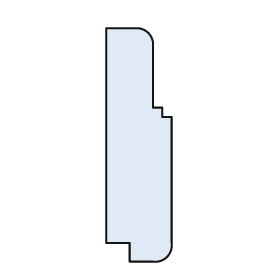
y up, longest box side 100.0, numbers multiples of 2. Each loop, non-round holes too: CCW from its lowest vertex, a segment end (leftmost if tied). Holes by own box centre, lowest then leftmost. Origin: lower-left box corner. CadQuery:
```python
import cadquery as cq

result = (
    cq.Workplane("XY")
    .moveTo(10.0, 0.0)
    .lineTo(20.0, 0.0)
    .threePointArc((26.0, 2.0), (28.0, 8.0))
    .lineTo(28.0, 62.0)
    .lineTo(24.0, 62.0)
    .lineTo(24.0, 66.0)
    .lineTo(20.0, 66.0)
    .lineTo(20.0, 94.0)
    .threePointArc((18.0, 98.0), (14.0, 100.0))
    .lineTo(0.0, 100.0)
    .lineTo(0.0, 8.0)
    .lineTo(10.0, 8.0)
    .close()
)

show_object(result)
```